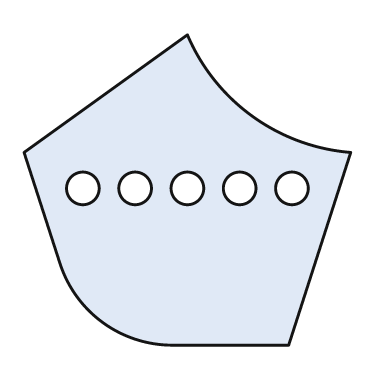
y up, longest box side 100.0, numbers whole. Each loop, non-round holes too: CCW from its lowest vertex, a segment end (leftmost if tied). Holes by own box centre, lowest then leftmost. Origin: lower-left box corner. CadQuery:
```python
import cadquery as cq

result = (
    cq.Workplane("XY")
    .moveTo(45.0, 0.0)
    .lineTo(81.0, 0.0)
    .lineTo(100.0, 59.0)
    .threePointArc((70.0, 70.0), (50.0, 95.0))
    .lineTo(0.0, 59.0)
    .lineTo(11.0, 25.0)
    .threePointArc((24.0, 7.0), (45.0, 0.0))
    .close()
    .moveTo(18.0, 48.0)
    .circle(5.0)
    .moveTo(34.0, 48.0)
    .circle(5.0)
    .moveTo(50.0, 48.0)
    .circle(5.0)
    .moveTo(66.0, 48.0)
    .circle(5.0)
    .moveTo(82.0, 48.0)
    .circle(5.0)
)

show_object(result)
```